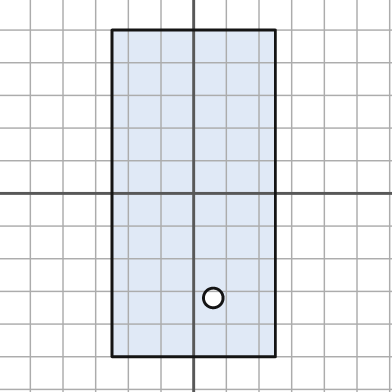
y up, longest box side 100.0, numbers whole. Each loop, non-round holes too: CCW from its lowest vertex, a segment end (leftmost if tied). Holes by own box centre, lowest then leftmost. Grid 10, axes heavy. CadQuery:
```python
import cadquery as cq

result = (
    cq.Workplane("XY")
    .moveTo(-25.0, -50.0)
    .lineTo(25.0, -50.0)
    .lineTo(25.0, 50.0)
    .lineTo(-25.0, 50.0)
    .close()
    .moveTo(6.0, -32.0)
    .circle(3.0)
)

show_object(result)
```